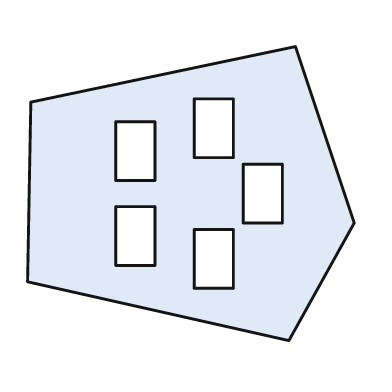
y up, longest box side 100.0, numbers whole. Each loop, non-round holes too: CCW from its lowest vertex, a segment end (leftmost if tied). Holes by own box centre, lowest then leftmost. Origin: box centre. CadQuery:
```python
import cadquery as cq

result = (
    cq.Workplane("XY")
    .moveTo(30.0, -45.0)
    .lineTo(50.0, -9.0)
    .lineTo(32.0, 45.0)
    .lineTo(-49.0, 28.0)
    .lineTo(-50.0, -27.0)
    .close()
    .moveTo(1.0, -29.0)
    .lineTo(13.0, -29.0)
    .lineTo(13.0, -11.0)
    .lineTo(1.0, -11.0)
    .close()
    .moveTo(-23.0, -22.0)
    .lineTo(-11.0, -22.0)
    .lineTo(-11.0, -4.0)
    .lineTo(-23.0, -4.0)
    .close()
    .moveTo(16.0, -9.0)
    .lineTo(28.0, -9.0)
    .lineTo(28.0, 9.0)
    .lineTo(16.0, 9.0)
    .close()
    .moveTo(-23.0, 4.0)
    .lineTo(-11.0, 4.0)
    .lineTo(-11.0, 22.0)
    .lineTo(-23.0, 22.0)
    .close()
    .moveTo(1.0, 11.0)
    .lineTo(13.0, 11.0)
    .lineTo(13.0, 29.0)
    .lineTo(1.0, 29.0)
    .close()
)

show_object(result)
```